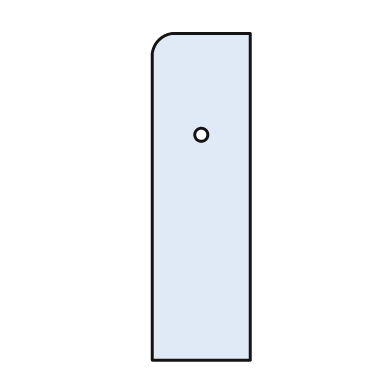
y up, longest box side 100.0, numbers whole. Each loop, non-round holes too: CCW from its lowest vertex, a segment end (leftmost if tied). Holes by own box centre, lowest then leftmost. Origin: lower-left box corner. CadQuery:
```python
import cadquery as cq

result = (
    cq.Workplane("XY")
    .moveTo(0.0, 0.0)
    .lineTo(30.0, 0.0)
    .lineTo(30.0, 100.0)
    .lineTo(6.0, 100.0)
    .threePointArc((2.0, 98.0), (0.0, 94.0))
    .close()
    .moveTo(15.0, 69.0)
    .circle(2.0)
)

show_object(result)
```